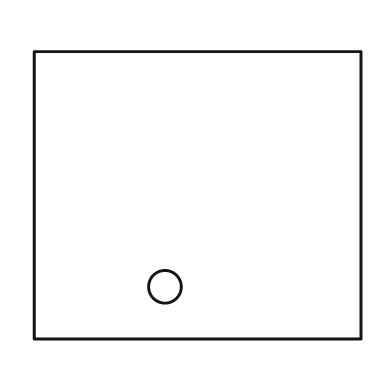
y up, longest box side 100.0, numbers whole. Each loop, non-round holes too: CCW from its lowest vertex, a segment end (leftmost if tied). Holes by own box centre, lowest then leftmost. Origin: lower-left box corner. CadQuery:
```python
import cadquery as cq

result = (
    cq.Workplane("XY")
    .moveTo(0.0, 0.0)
    .lineTo(100.0, 0.0)
    .lineTo(100.0, 88.0)
    .lineTo(0.0, 88.0)
    .close()
    .moveTo(40.0, 16.0)
    .circle(5.0)
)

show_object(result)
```